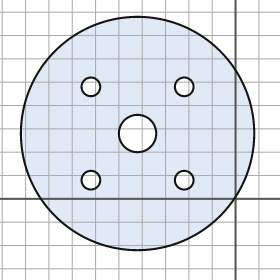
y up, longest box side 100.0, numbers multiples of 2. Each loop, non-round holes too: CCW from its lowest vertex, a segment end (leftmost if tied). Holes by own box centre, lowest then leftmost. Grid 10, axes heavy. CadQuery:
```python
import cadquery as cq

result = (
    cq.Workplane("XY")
    .moveTo(-42.0, 28.0)
    .circle(50.0)
    .moveTo(-62.0, 8.0)
    .circle(4.0)
    .moveTo(-22.0, 8.0)
    .circle(4.0)
    .moveTo(-42.0, 28.0)
    .circle(8.0)
    .moveTo(-62.0, 48.0)
    .circle(4.0)
    .moveTo(-22.0, 48.0)
    .circle(4.0)
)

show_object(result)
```